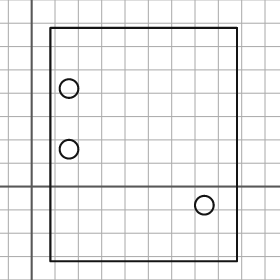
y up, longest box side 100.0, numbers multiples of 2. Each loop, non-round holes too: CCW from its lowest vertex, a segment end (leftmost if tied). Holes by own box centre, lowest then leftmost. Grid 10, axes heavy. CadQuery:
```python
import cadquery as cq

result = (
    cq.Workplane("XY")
    .moveTo(8.0, -32.0)
    .lineTo(88.0, -32.0)
    .lineTo(88.0, 68.0)
    .lineTo(8.0, 68.0)
    .close()
    .moveTo(74.0, -8.0)
    .circle(4.0)
    .moveTo(16.0, 16.0)
    .circle(4.0)
    .moveTo(16.0, 42.0)
    .circle(4.0)
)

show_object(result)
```